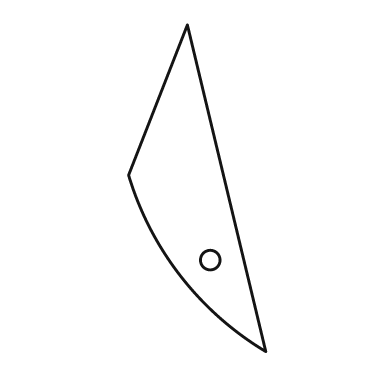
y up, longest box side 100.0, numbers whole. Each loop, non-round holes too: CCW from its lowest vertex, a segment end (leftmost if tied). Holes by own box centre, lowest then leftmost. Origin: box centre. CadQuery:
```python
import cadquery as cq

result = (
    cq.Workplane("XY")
    .moveTo(21.0, -50.0)
    .lineTo(-3.0, 50.0)
    .lineTo(-21.0, 4.0)
    .threePointArc((-5.0, -27.0), (21.0, -50.0))
    .close()
    .moveTo(4.0, -22.0)
    .circle(3.0)
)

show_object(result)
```